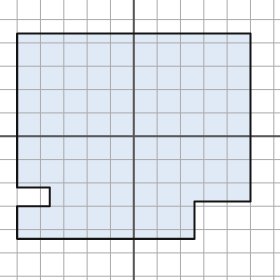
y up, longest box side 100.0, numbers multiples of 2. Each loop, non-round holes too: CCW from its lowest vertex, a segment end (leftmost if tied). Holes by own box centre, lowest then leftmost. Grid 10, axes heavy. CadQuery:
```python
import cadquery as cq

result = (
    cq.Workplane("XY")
    .moveTo(-50.0, -44.0)
    .lineTo(26.0, -44.0)
    .lineTo(26.0, -28.0)
    .lineTo(50.0, -28.0)
    .lineTo(50.0, 44.0)
    .lineTo(-50.0, 44.0)
    .lineTo(-50.0, -22.0)
    .lineTo(-36.0, -22.0)
    .lineTo(-36.0, -30.0)
    .lineTo(-50.0, -30.0)
    .close()
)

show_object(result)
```